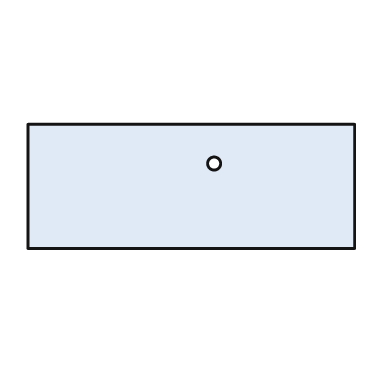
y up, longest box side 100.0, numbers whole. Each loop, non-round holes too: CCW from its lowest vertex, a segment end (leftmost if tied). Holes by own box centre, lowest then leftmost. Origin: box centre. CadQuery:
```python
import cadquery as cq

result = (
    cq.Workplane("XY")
    .moveTo(-50.0, -19.0)
    .lineTo(50.0, -19.0)
    .lineTo(50.0, 19.0)
    .lineTo(-50.0, 19.0)
    .close()
    .moveTo(7.0, 7.0)
    .circle(2.0)
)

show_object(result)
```